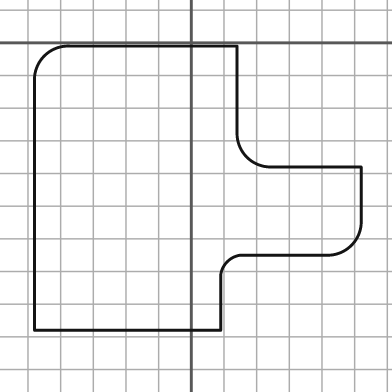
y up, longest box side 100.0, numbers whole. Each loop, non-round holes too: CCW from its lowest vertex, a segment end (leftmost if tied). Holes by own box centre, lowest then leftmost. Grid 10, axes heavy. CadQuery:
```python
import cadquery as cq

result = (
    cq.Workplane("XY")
    .moveTo(-48.0, -88.0)
    .lineTo(9.0, -88.0)
    .lineTo(9.0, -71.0)
    .threePointArc((11.0, -67.0), (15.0, -65.0))
    .lineTo(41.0, -65.0)
    .threePointArc((49.0, -62.0), (52.0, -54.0))
    .lineTo(52.0, -38.0)
    .lineTo(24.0, -38.0)
    .threePointArc((17.0, -35.0), (14.0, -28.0))
    .lineTo(14.0, -1.0)
    .lineTo(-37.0, -1.0)
    .threePointArc((-45.0, -4.0), (-48.0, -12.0))
    .close()
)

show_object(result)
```